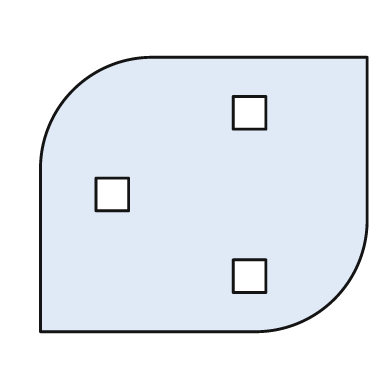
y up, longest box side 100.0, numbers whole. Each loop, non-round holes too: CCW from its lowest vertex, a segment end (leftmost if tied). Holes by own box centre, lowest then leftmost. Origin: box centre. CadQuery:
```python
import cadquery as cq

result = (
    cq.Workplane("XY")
    .moveTo(-50.0, -42.0)
    .lineTo(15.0, -42.0)
    .threePointArc((40.0, -32.0), (50.0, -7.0))
    .lineTo(50.0, 42.0)
    .lineTo(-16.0, 42.0)
    .threePointArc((-40.0, 32.0), (-50.0, 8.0))
    .close()
    .moveTo(9.0, -30.0)
    .lineTo(19.0, -30.0)
    .lineTo(19.0, -20.0)
    .lineTo(9.0, -20.0)
    .close()
    .moveTo(-33.0, -5.0)
    .lineTo(-23.0, -5.0)
    .lineTo(-23.0, 5.0)
    .lineTo(-33.0, 5.0)
    .close()
    .moveTo(9.0, 20.0)
    .lineTo(19.0, 20.0)
    .lineTo(19.0, 30.0)
    .lineTo(9.0, 30.0)
    .close()
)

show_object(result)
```